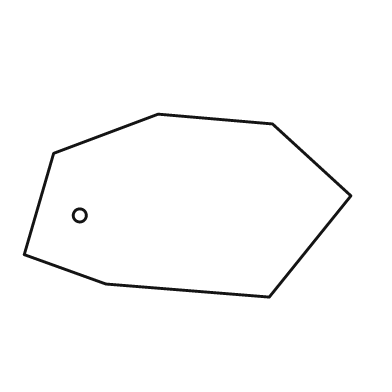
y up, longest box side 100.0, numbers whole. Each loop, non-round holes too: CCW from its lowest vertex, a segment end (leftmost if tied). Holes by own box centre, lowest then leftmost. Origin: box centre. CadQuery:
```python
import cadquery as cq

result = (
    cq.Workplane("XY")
    .moveTo(25.0, -28.0)
    .lineTo(50.0, 3.0)
    .lineTo(26.0, 25.0)
    .lineTo(-9.0, 28.0)
    .lineTo(-41.0, 16.0)
    .lineTo(-50.0, -15.0)
    .lineTo(-25.0, -24.0)
    .close()
    .moveTo(-33.0, -3.0)
    .circle(2.0)
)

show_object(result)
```